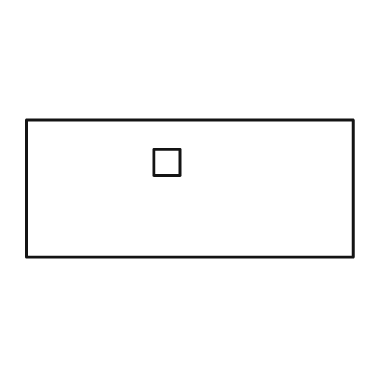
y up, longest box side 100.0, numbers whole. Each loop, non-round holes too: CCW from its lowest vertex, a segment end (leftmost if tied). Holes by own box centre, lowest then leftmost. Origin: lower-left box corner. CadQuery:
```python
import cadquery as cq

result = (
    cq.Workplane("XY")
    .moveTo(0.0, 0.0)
    .lineTo(100.0, 0.0)
    .lineTo(100.0, 42.0)
    .lineTo(0.0, 42.0)
    .close()
    .moveTo(39.0, 25.0)
    .lineTo(47.0, 25.0)
    .lineTo(47.0, 33.0)
    .lineTo(39.0, 33.0)
    .close()
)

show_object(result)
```